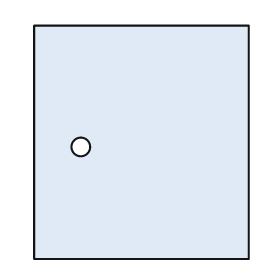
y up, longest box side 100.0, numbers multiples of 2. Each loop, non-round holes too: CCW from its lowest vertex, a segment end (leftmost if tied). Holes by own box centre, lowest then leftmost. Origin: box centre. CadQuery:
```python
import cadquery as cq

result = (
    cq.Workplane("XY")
    .moveTo(-46.0, -50.0)
    .lineTo(46.0, -50.0)
    .lineTo(46.0, 50.0)
    .lineTo(-46.0, 50.0)
    .close()
    .moveTo(-26.0, -2.0)
    .circle(4.0)
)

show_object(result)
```